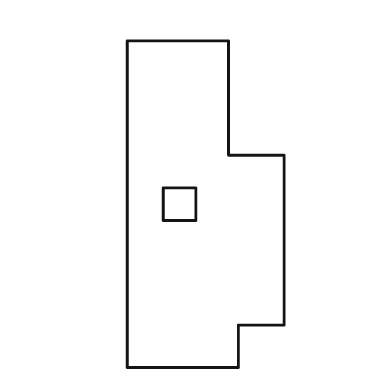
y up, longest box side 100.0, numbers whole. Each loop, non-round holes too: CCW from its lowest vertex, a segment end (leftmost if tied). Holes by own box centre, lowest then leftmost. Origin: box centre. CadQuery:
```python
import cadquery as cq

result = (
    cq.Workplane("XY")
    .moveTo(-24.0, -50.0)
    .lineTo(10.0, -50.0)
    .lineTo(10.0, -37.0)
    .lineTo(24.0, -37.0)
    .lineTo(24.0, 15.0)
    .lineTo(7.0, 15.0)
    .lineTo(7.0, 50.0)
    .lineTo(-24.0, 50.0)
    .close()
    .moveTo(-13.0, -5.0)
    .lineTo(-3.0, -5.0)
    .lineTo(-3.0, 5.0)
    .lineTo(-13.0, 5.0)
    .close()
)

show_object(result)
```